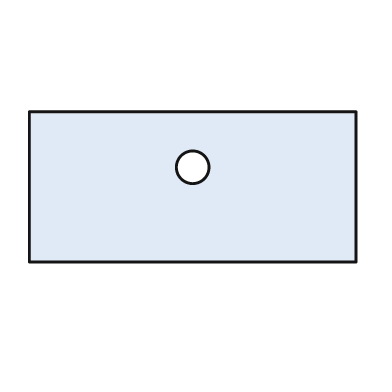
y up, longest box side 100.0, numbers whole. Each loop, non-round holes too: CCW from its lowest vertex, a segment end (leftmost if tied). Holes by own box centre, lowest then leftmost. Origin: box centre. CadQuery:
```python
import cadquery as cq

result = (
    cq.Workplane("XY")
    .moveTo(-50.0, -23.0)
    .lineTo(50.0, -23.0)
    .lineTo(50.0, 23.0)
    .lineTo(-50.0, 23.0)
    .close()
    .moveTo(0.0, 6.0)
    .circle(5.0)
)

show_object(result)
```